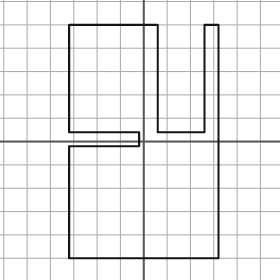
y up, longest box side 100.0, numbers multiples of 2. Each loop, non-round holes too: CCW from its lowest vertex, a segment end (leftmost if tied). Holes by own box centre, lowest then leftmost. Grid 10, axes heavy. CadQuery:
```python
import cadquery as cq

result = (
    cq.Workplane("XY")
    .moveTo(-32.0, -50.0)
    .lineTo(32.0, -50.0)
    .lineTo(32.0, 50.0)
    .lineTo(26.0, 50.0)
    .lineTo(26.0, 4.0)
    .lineTo(6.0, 4.0)
    .lineTo(6.0, 50.0)
    .lineTo(-32.0, 50.0)
    .lineTo(-32.0, 4.0)
    .lineTo(-2.0, 4.0)
    .lineTo(-2.0, -2.0)
    .lineTo(-32.0, -2.0)
    .close()
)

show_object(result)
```